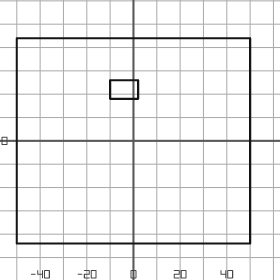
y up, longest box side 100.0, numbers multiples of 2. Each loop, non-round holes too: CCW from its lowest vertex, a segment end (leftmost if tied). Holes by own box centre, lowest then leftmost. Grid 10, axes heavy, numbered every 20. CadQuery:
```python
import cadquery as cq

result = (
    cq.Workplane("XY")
    .moveTo(-50.0, -44.0)
    .lineTo(50.0, -44.0)
    .lineTo(50.0, 44.0)
    .lineTo(-50.0, 44.0)
    .close()
    .moveTo(-10.0, 18.0)
    .lineTo(2.0, 18.0)
    .lineTo(2.0, 26.0)
    .lineTo(-10.0, 26.0)
    .close()
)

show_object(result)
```